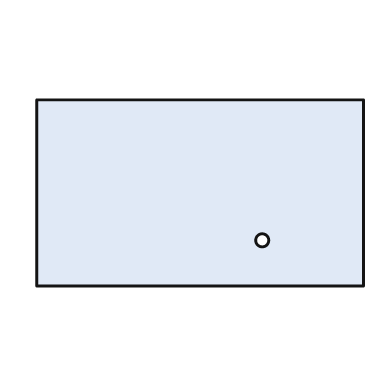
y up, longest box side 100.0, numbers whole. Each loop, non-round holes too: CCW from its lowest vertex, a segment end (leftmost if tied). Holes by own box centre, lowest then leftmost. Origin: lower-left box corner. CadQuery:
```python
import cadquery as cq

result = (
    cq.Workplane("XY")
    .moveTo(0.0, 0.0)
    .lineTo(100.0, 0.0)
    .lineTo(100.0, 57.0)
    .lineTo(0.0, 57.0)
    .close()
    .moveTo(69.0, 14.0)
    .circle(2.0)
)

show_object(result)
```